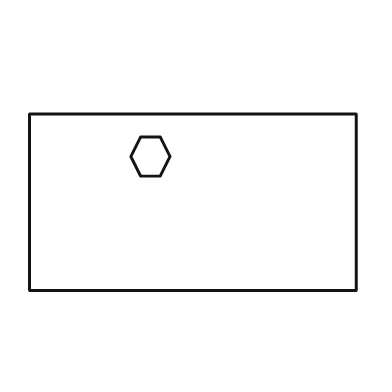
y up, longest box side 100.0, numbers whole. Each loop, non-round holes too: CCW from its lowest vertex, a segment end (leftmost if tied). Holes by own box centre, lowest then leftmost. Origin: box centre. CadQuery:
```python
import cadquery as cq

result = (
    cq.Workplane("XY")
    .moveTo(-50.0, -27.0)
    .lineTo(50.0, -27.0)
    .lineTo(50.0, 27.0)
    .lineTo(-50.0, 27.0)
    .close()
    .moveTo(-16.0, 8.0)
    .lineTo(-10.0, 8.0)
    .lineTo(-7.0, 14.0)
    .lineTo(-10.0, 20.0)
    .lineTo(-16.0, 20.0)
    .lineTo(-19.0, 14.0)
    .close()
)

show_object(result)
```